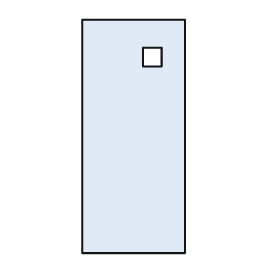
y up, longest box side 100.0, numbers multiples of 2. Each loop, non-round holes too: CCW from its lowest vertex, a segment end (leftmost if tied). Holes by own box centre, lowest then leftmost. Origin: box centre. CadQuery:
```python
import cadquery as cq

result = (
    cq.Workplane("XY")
    .moveTo(-22.0, -50.0)
    .lineTo(22.0, -50.0)
    .lineTo(22.0, 50.0)
    .lineTo(-22.0, 50.0)
    .close()
    .moveTo(4.0, 30.0)
    .lineTo(12.0, 30.0)
    .lineTo(12.0, 38.0)
    .lineTo(4.0, 38.0)
    .close()
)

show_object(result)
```